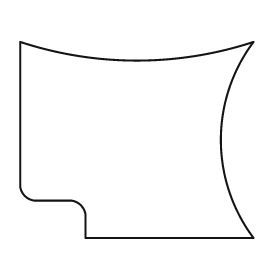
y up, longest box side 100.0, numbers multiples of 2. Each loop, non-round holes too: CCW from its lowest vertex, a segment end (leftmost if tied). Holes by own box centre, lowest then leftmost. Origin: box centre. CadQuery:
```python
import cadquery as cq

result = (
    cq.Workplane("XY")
    .moveTo(-22.0, -42.0)
    .lineTo(50.0, -42.0)
    .threePointArc((36.0, 0.0), (50.0, 42.0))
    .threePointArc((0.0, 34.0), (-50.0, 42.0))
    .lineTo(-50.0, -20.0)
    .threePointArc((-48.0, -24.0), (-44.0, -26.0))
    .lineTo(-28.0, -26.0)
    .threePointArc((-24.0, -28.0), (-22.0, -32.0))
    .close()
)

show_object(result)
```